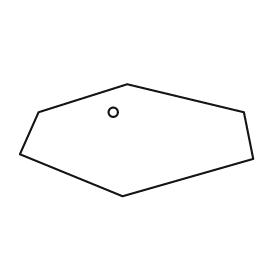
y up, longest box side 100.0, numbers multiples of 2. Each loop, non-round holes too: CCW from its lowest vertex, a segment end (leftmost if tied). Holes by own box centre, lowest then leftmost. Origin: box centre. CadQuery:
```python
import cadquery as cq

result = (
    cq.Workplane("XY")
    .moveTo(-6.0, -24.0)
    .lineTo(50.0, -8.0)
    .lineTo(46.0, 12.0)
    .lineTo(-4.0, 24.0)
    .lineTo(-42.0, 12.0)
    .lineTo(-50.0, -6.0)
    .close()
    .moveTo(-10.0, 12.0)
    .circle(2.0)
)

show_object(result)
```